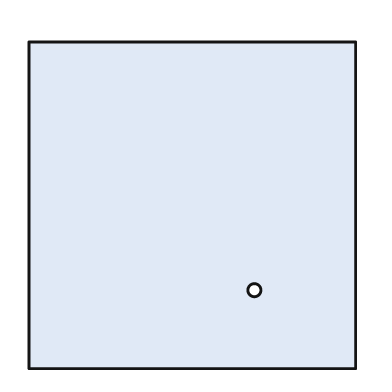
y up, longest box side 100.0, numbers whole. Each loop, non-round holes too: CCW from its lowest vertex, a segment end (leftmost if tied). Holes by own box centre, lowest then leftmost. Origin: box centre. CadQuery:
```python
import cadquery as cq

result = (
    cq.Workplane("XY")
    .moveTo(-50.0, -50.0)
    .lineTo(50.0, -50.0)
    .lineTo(50.0, 50.0)
    .lineTo(-50.0, 50.0)
    .close()
    .moveTo(19.0, -26.0)
    .circle(2.0)
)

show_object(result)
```